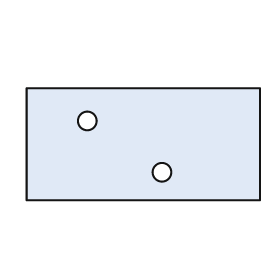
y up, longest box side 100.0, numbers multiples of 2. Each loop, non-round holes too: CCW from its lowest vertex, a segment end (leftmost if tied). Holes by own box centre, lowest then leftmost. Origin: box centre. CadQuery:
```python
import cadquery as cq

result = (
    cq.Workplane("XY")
    .moveTo(-50.0, -24.0)
    .lineTo(50.0, -24.0)
    .lineTo(50.0, 24.0)
    .lineTo(-50.0, 24.0)
    .close()
    .moveTo(8.0, -12.0)
    .circle(4.0)
    .moveTo(-24.0, 10.0)
    .circle(4.0)
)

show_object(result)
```